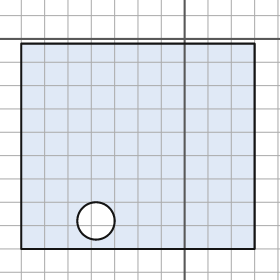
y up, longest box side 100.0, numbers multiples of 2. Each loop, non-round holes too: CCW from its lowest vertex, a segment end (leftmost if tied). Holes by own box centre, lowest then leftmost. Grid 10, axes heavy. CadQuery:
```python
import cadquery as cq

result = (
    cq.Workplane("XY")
    .moveTo(-70.0, -90.0)
    .lineTo(30.0, -90.0)
    .lineTo(30.0, -2.0)
    .lineTo(-70.0, -2.0)
    .close()
    .moveTo(-38.0, -78.0)
    .circle(8.0)
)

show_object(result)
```